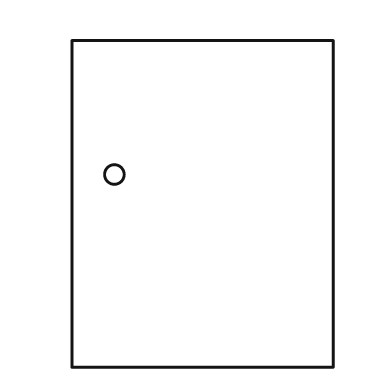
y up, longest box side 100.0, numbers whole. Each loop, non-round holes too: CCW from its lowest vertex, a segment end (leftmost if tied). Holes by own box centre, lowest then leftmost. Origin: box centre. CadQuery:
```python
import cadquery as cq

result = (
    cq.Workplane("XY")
    .moveTo(-40.0, -50.0)
    .lineTo(40.0, -50.0)
    .lineTo(40.0, 50.0)
    .lineTo(-40.0, 50.0)
    .close()
    .moveTo(-27.0, 9.0)
    .circle(3.0)
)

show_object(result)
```